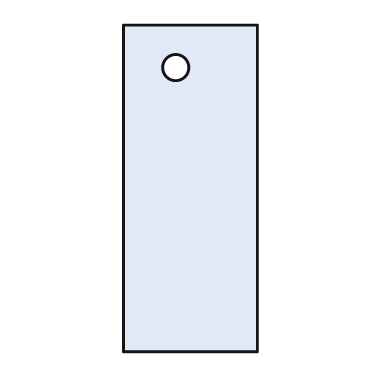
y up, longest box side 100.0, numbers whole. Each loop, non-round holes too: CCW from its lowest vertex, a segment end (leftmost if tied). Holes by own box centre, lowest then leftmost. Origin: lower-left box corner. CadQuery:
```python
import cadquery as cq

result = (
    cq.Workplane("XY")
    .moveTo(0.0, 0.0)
    .lineTo(41.0, 0.0)
    .lineTo(41.0, 100.0)
    .lineTo(0.0, 100.0)
    .close()
    .moveTo(16.0, 87.0)
    .circle(4.0)
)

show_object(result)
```